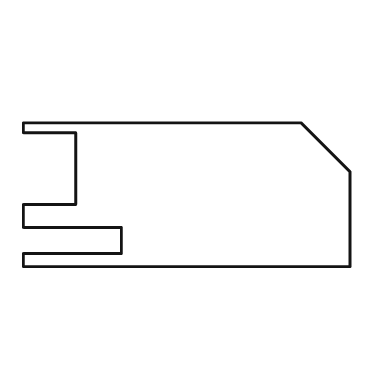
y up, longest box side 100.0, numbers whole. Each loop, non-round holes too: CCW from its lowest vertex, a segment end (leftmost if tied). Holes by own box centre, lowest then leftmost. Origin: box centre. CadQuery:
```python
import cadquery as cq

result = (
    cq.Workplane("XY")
    .moveTo(-50.0, -22.0)
    .lineTo(50.0, -22.0)
    .lineTo(50.0, 7.0)
    .lineTo(35.0, 22.0)
    .lineTo(-50.0, 22.0)
    .lineTo(-50.0, 19.0)
    .lineTo(-34.0, 19.0)
    .lineTo(-34.0, -3.0)
    .lineTo(-50.0, -3.0)
    .lineTo(-50.0, -10.0)
    .lineTo(-20.0, -10.0)
    .lineTo(-20.0, -18.0)
    .lineTo(-50.0, -18.0)
    .close()
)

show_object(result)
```